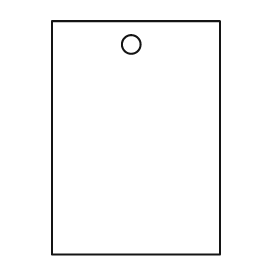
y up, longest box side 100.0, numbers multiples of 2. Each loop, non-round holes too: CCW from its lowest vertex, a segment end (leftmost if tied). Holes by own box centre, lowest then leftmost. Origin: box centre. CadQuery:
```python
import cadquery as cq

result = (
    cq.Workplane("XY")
    .moveTo(-36.0, -50.0)
    .lineTo(36.0, -50.0)
    .lineTo(36.0, 50.0)
    .lineTo(-36.0, 50.0)
    .close()
    .moveTo(-2.0, 40.0)
    .circle(4.0)
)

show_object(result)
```